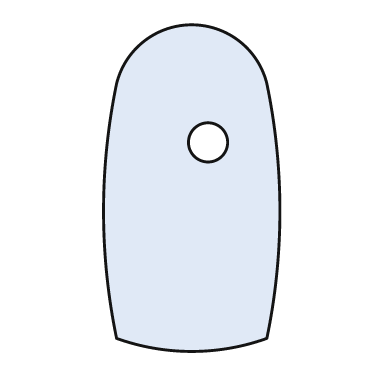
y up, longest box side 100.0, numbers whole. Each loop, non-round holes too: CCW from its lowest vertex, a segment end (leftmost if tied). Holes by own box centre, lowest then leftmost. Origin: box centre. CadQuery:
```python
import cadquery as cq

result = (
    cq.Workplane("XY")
    .moveTo(-23.0, -46.0)
    .threePointArc((0.0, -50.0), (23.0, -46.0))
    .threePointArc((27.0, -7.0), (23.0, 32.0))
    .threePointArc((0.0, 50.0), (-23.0, 32.0))
    .threePointArc((-27.0, -7.0), (-23.0, -46.0))
    .close()
    .moveTo(5.0, 14.0)
    .circle(6.0)
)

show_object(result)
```